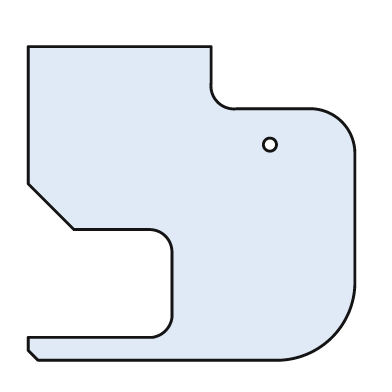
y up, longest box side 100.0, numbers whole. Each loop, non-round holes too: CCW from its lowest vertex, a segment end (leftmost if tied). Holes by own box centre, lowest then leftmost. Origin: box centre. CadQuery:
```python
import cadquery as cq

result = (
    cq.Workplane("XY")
    .moveTo(-47.0, -48.0)
    .lineTo(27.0, -48.0)
    .threePointArc((43.0, -41.0), (50.0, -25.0))
    .lineTo(50.0, 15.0)
    .threePointArc((46.0, 25.0), (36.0, 29.0))
    .lineTo(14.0, 29.0)
    .threePointArc((8.0, 31.0), (6.0, 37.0))
    .lineTo(6.0, 48.0)
    .lineTo(-50.0, 48.0)
    .lineTo(-50.0, 6.0)
    .lineTo(-36.0, -8.0)
    .lineTo(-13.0, -8.0)
    .threePointArc((-8.0, -10.0), (-6.0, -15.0))
    .lineTo(-6.0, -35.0)
    .threePointArc((-8.0, -39.0), (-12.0, -41.0))
    .lineTo(-50.0, -41.0)
    .lineTo(-50.0, -45.0)
    .close()
    .moveTo(24.0, 18.0)
    .circle(2.0)
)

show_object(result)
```